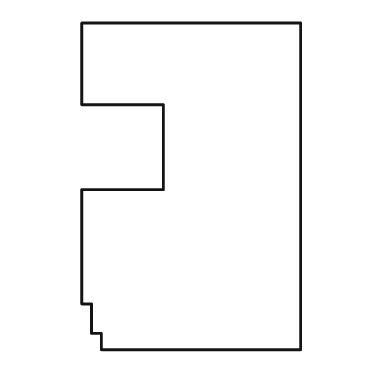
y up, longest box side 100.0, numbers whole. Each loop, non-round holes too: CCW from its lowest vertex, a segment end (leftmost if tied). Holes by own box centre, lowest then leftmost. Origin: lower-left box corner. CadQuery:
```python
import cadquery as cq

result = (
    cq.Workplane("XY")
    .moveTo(6.0, 0.0)
    .lineTo(67.0, 0.0)
    .lineTo(67.0, 100.0)
    .lineTo(0.0, 100.0)
    .lineTo(0.0, 75.0)
    .lineTo(25.0, 75.0)
    .lineTo(25.0, 49.0)
    .lineTo(0.0, 49.0)
    .lineTo(0.0, 14.0)
    .lineTo(3.0, 14.0)
    .lineTo(3.0, 5.0)
    .lineTo(6.0, 5.0)
    .close()
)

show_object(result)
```